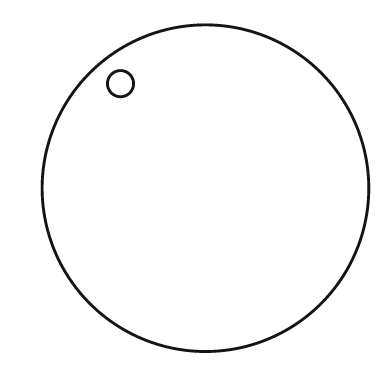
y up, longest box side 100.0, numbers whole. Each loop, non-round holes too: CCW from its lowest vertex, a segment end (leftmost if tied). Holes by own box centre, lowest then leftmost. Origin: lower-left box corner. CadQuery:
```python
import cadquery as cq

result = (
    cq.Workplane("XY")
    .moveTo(50.0, 50.0)
    .circle(50.0)
    .moveTo(24.0, 82.0)
    .circle(4.0)
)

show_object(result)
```